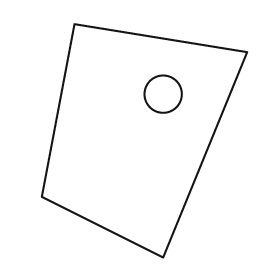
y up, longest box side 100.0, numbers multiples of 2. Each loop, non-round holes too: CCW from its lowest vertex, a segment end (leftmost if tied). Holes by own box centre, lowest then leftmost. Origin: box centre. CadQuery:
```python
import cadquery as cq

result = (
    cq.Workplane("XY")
    .moveTo(8.0, -50.0)
    .lineTo(44.0, 38.0)
    .lineTo(-30.0, 50.0)
    .lineTo(-44.0, -24.0)
    .close()
    .moveTo(8.0, 20.0)
    .circle(8.0)
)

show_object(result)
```